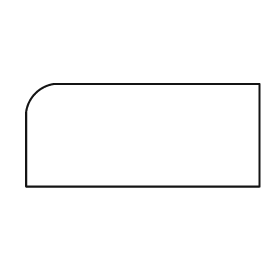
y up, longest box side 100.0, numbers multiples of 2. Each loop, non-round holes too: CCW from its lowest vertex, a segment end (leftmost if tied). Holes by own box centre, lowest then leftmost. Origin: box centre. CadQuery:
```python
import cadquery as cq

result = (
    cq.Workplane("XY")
    .moveTo(-50.0, -22.0)
    .lineTo(50.0, -22.0)
    .lineTo(50.0, 22.0)
    .lineTo(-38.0, 22.0)
    .threePointArc((-46.0, 18.0), (-50.0, 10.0))
    .close()
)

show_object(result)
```